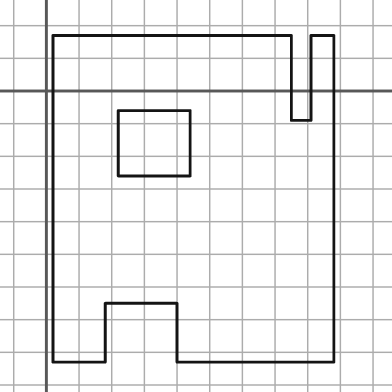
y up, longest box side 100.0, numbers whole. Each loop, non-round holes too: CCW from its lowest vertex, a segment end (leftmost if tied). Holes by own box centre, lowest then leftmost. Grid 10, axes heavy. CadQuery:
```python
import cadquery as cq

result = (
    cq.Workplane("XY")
    .moveTo(2.0, -83.0)
    .lineTo(18.0, -83.0)
    .lineTo(18.0, -65.0)
    .lineTo(40.0, -65.0)
    .lineTo(40.0, -83.0)
    .lineTo(88.0, -83.0)
    .lineTo(88.0, 17.0)
    .lineTo(81.0, 17.0)
    .lineTo(81.0, -9.0)
    .lineTo(75.0, -9.0)
    .lineTo(75.0, 17.0)
    .lineTo(2.0, 17.0)
    .close()
    .moveTo(22.0, -26.0)
    .lineTo(44.0, -26.0)
    .lineTo(44.0, -6.0)
    .lineTo(22.0, -6.0)
    .close()
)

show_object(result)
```